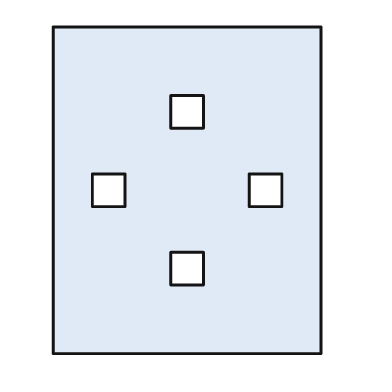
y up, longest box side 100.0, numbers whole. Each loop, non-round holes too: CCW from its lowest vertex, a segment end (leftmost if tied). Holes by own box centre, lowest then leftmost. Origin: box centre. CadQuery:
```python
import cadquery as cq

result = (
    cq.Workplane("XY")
    .moveTo(-41.0, -50.0)
    .lineTo(41.0, -50.0)
    .lineTo(41.0, 50.0)
    .lineTo(-41.0, 50.0)
    .close()
    .moveTo(-5.0, -29.0)
    .lineTo(5.0, -29.0)
    .lineTo(5.0, -19.0)
    .lineTo(-5.0, -19.0)
    .close()
    .moveTo(-29.0, -5.0)
    .lineTo(-19.0, -5.0)
    .lineTo(-19.0, 5.0)
    .lineTo(-29.0, 5.0)
    .close()
    .moveTo(19.0, -5.0)
    .lineTo(29.0, -5.0)
    .lineTo(29.0, 5.0)
    .lineTo(19.0, 5.0)
    .close()
    .moveTo(-5.0, 19.0)
    .lineTo(5.0, 19.0)
    .lineTo(5.0, 29.0)
    .lineTo(-5.0, 29.0)
    .close()
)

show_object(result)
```